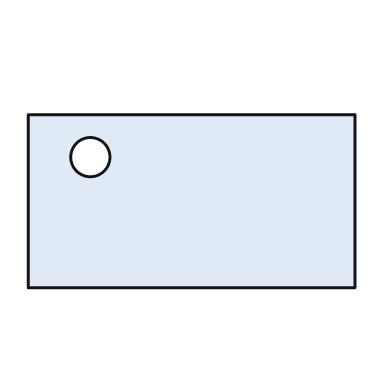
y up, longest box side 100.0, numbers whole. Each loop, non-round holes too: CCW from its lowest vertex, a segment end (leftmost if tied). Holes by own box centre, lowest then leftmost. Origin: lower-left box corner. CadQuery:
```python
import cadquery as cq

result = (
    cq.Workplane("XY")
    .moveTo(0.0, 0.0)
    .lineTo(100.0, 0.0)
    .lineTo(100.0, 53.0)
    .lineTo(0.0, 53.0)
    .close()
    .moveTo(19.0, 40.0)
    .circle(6.0)
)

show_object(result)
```